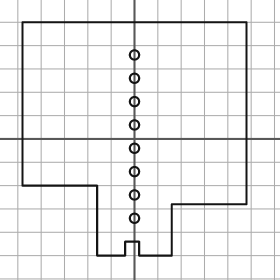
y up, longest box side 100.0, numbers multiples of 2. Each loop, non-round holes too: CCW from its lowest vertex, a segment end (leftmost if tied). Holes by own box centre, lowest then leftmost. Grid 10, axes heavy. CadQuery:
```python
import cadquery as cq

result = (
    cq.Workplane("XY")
    .moveTo(-16.0, -50.0)
    .lineTo(-4.0, -50.0)
    .lineTo(-4.0, -44.0)
    .lineTo(2.0, -44.0)
    .lineTo(2.0, -50.0)
    .lineTo(16.0, -50.0)
    .lineTo(16.0, -28.0)
    .lineTo(48.0, -28.0)
    .lineTo(48.0, 50.0)
    .lineTo(-48.0, 50.0)
    .lineTo(-48.0, -20.0)
    .lineTo(-16.0, -20.0)
    .close()
    .moveTo(0.0, -34.0)
    .circle(2.0)
    .moveTo(0.0, -24.0)
    .circle(2.0)
    .moveTo(0.0, -14.0)
    .circle(2.0)
    .moveTo(0.0, -4.0)
    .circle(2.0)
    .moveTo(0.0, 6.0)
    .circle(2.0)
    .moveTo(0.0, 16.0)
    .circle(2.0)
    .moveTo(0.0, 26.0)
    .circle(2.0)
    .moveTo(0.0, 36.0)
    .circle(2.0)
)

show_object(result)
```